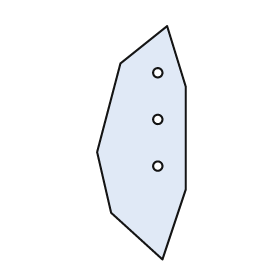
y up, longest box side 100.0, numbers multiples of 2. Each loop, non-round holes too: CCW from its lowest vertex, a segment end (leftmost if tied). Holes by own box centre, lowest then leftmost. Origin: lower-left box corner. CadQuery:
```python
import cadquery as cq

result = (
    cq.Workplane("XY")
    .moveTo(28.0, 0.0)
    .lineTo(38.0, 30.0)
    .lineTo(38.0, 74.0)
    .lineTo(30.0, 100.0)
    .lineTo(10.0, 84.0)
    .lineTo(0.0, 46.0)
    .lineTo(6.0, 20.0)
    .close()
    .moveTo(26.0, 40.0)
    .circle(2.0)
    .moveTo(26.0, 60.0)
    .circle(2.0)
    .moveTo(26.0, 80.0)
    .circle(2.0)
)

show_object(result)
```